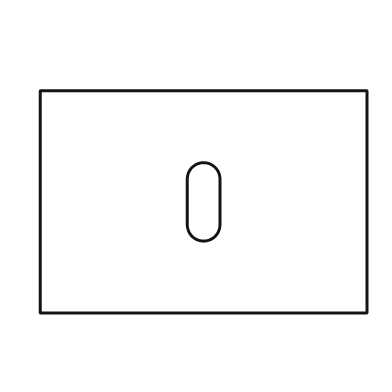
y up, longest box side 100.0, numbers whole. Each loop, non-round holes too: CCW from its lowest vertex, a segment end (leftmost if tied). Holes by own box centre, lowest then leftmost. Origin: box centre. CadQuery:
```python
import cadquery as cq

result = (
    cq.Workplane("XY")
    .moveTo(-50.0, -34.0)
    .lineTo(50.0, -34.0)
    .lineTo(50.0, 34.0)
    .lineTo(-50.0, 34.0)
    .close()
    .moveTo(-5.0, -7.0)
    .threePointArc((0.0, -12.0), (5.0, -7.0))
    .lineTo(5.0, 7.0)
    .threePointArc((0.0, 12.0), (-5.0, 7.0))
    .close()
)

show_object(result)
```